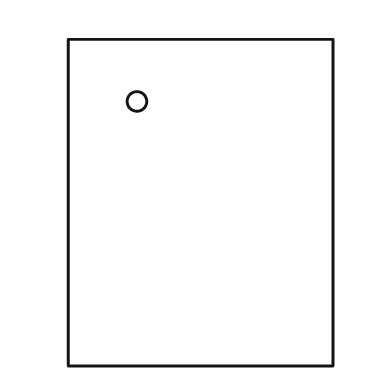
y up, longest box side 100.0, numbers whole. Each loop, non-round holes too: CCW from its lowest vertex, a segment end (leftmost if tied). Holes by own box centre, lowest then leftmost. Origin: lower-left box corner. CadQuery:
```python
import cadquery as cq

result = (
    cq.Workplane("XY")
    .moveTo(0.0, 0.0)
    .lineTo(81.0, 0.0)
    .lineTo(81.0, 100.0)
    .lineTo(0.0, 100.0)
    .close()
    .moveTo(21.0, 81.0)
    .circle(3.0)
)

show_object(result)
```